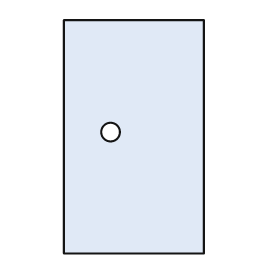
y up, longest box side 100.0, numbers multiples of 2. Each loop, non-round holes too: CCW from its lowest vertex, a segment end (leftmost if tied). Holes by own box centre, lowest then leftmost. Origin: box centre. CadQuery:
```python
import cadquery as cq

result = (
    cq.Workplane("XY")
    .moveTo(-30.0, -50.0)
    .lineTo(30.0, -50.0)
    .lineTo(30.0, 50.0)
    .lineTo(-30.0, 50.0)
    .close()
    .moveTo(-10.0, 2.0)
    .circle(4.0)
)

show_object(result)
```